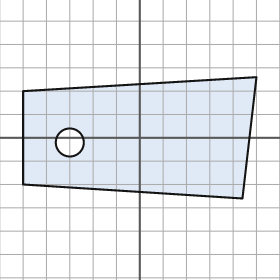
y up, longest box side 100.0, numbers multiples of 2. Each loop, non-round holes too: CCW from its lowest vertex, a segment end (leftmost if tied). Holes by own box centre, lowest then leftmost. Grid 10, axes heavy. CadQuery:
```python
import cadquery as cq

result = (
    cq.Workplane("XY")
    .moveTo(44.0, -26.0)
    .lineTo(50.0, 26.0)
    .lineTo(-50.0, 20.0)
    .lineTo(-50.0, -20.0)
    .close()
    .moveTo(-30.0, -2.0)
    .circle(6.0)
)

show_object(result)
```